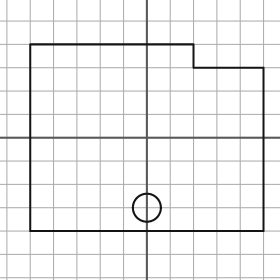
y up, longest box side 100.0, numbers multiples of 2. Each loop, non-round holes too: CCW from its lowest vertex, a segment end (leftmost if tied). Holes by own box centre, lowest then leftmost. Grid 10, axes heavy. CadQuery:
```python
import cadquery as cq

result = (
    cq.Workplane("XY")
    .moveTo(-50.0, -40.0)
    .lineTo(50.0, -40.0)
    .lineTo(50.0, 30.0)
    .lineTo(20.0, 30.0)
    .lineTo(20.0, 40.0)
    .lineTo(-50.0, 40.0)
    .close()
    .moveTo(0.0, -30.0)
    .circle(6.0)
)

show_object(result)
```